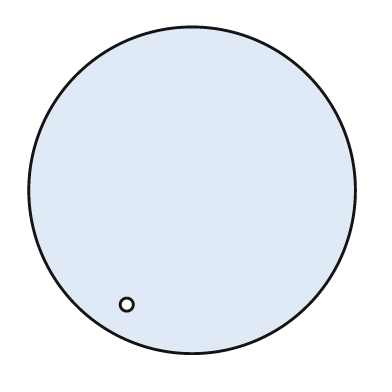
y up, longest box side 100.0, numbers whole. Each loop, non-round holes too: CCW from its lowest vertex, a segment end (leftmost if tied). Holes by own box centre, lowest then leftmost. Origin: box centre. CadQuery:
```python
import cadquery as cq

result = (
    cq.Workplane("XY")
    .moveTo(0.0, 0.0)
    .circle(50.0)
    .moveTo(-20.0, -35.0)
    .circle(2.0)
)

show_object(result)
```